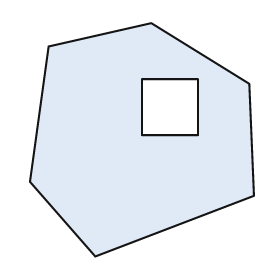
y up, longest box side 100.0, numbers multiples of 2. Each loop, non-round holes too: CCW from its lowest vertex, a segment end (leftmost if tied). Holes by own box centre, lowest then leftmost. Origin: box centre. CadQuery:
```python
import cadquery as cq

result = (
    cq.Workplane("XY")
    .moveTo(-20.0, -50.0)
    .lineTo(48.0, -24.0)
    .lineTo(46.0, 24.0)
    .lineTo(4.0, 50.0)
    .lineTo(-40.0, 40.0)
    .lineTo(-48.0, -18.0)
    .close()
    .moveTo(0.0, 2.0)
    .lineTo(24.0, 2.0)
    .lineTo(24.0, 26.0)
    .lineTo(0.0, 26.0)
    .close()
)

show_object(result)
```